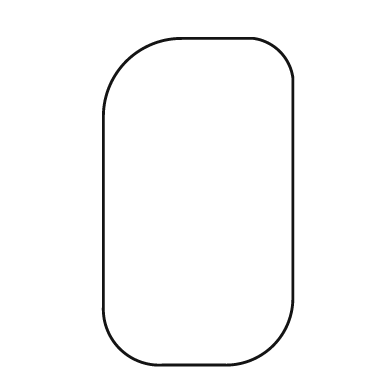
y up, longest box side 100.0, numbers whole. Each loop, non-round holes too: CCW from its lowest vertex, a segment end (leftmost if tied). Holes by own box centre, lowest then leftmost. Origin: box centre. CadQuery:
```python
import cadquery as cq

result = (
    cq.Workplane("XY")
    .moveTo(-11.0, -50.0)
    .lineTo(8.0, -50.0)
    .threePointArc((23.0, -44.0), (29.0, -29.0))
    .lineTo(29.0, 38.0)
    .threePointArc((25.0, 46.0), (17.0, 50.0))
    .lineTo(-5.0, 50.0)
    .threePointArc((-22.0, 43.0), (-29.0, 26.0))
    .lineTo(-29.0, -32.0)
    .threePointArc((-24.0, -45.0), (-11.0, -50.0))
    .close()
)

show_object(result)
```